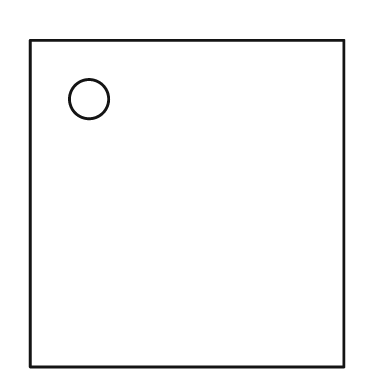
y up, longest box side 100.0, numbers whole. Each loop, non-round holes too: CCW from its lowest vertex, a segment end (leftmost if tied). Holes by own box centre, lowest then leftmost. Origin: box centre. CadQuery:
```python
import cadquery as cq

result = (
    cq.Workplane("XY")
    .moveTo(-48.0, -50.0)
    .lineTo(48.0, -50.0)
    .lineTo(48.0, 50.0)
    .lineTo(-48.0, 50.0)
    .close()
    .moveTo(-30.0, 32.0)
    .circle(6.0)
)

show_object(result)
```